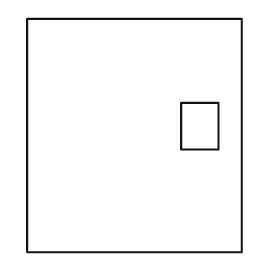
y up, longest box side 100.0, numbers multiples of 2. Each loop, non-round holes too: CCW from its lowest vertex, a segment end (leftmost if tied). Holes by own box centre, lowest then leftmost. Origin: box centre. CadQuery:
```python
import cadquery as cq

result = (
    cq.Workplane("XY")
    .moveTo(-46.0, -50.0)
    .lineTo(46.0, -50.0)
    .lineTo(46.0, 50.0)
    .lineTo(-46.0, 50.0)
    .close()
    .moveTo(20.0, -6.0)
    .lineTo(36.0, -6.0)
    .lineTo(36.0, 14.0)
    .lineTo(20.0, 14.0)
    .close()
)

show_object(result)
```